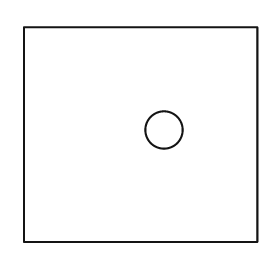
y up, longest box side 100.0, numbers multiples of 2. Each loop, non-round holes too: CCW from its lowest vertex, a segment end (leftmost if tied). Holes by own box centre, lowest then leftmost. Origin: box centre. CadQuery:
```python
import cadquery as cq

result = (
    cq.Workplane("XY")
    .moveTo(-50.0, -46.0)
    .lineTo(50.0, -46.0)
    .lineTo(50.0, 46.0)
    .lineTo(-50.0, 46.0)
    .close()
    .moveTo(10.0, 2.0)
    .circle(8.0)
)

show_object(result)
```